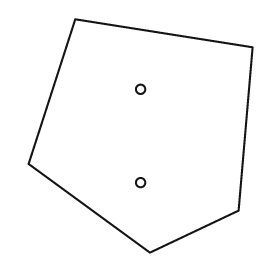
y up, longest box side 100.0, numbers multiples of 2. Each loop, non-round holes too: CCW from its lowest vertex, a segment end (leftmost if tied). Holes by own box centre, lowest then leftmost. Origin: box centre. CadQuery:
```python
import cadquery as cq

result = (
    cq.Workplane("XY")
    .moveTo(4.0, -50.0)
    .lineTo(42.0, -32.0)
    .lineTo(48.0, 38.0)
    .lineTo(-28.0, 50.0)
    .lineTo(-48.0, -12.0)
    .close()
    .moveTo(0.0, -20.0)
    .circle(2.0)
    .moveTo(0.0, 20.0)
    .circle(2.0)
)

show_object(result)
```